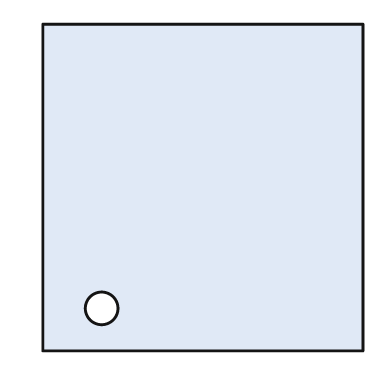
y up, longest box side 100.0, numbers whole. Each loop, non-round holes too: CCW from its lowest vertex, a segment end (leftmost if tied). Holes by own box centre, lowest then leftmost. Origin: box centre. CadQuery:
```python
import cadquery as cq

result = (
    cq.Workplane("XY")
    .moveTo(-49.0, -50.0)
    .lineTo(49.0, -50.0)
    .lineTo(49.0, 50.0)
    .lineTo(-49.0, 50.0)
    .close()
    .moveTo(-31.0, -37.0)
    .circle(5.0)
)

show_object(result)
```